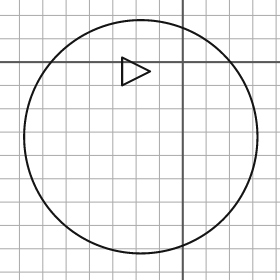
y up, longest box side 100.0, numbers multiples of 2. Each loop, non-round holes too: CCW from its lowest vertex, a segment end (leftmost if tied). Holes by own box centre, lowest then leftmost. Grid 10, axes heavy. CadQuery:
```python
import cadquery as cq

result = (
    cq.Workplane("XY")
    .moveTo(-18.0, -32.0)
    .circle(50.0)
    .moveTo(-26.0, -10.0)
    .lineTo(-14.0, -4.0)
    .lineTo(-26.0, 2.0)
    .close()
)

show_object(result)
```